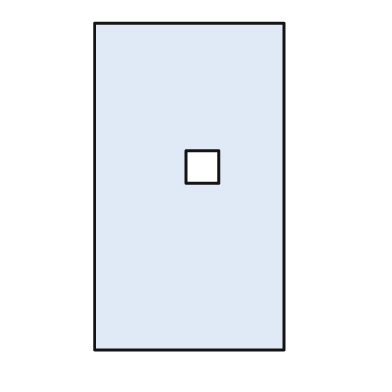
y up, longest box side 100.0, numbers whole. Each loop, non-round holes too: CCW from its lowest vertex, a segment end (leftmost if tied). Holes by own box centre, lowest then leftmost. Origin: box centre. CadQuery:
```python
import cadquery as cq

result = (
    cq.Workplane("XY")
    .moveTo(-29.0, -50.0)
    .lineTo(29.0, -50.0)
    .lineTo(29.0, 50.0)
    .lineTo(-29.0, 50.0)
    .close()
    .moveTo(-1.0, 1.0)
    .lineTo(9.0, 1.0)
    .lineTo(9.0, 11.0)
    .lineTo(-1.0, 11.0)
    .close()
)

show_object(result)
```